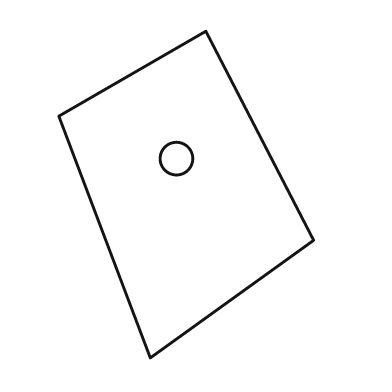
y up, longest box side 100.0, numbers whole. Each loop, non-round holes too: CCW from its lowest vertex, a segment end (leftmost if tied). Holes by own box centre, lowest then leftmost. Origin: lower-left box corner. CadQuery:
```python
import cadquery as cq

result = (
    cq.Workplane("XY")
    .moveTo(28.0, 0.0)
    .lineTo(78.0, 36.0)
    .lineTo(45.0, 100.0)
    .lineTo(0.0, 74.0)
    .close()
    .moveTo(36.0, 61.0)
    .circle(5.0)
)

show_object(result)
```